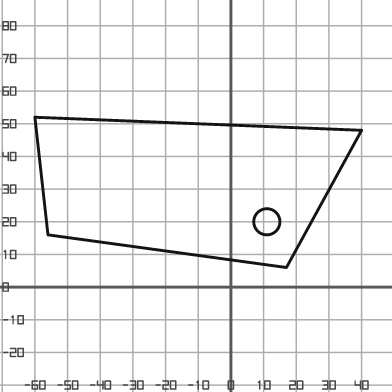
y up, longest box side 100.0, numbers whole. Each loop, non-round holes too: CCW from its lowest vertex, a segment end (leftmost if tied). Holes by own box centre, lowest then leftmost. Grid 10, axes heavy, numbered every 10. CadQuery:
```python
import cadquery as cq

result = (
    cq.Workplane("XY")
    .moveTo(17.0, 6.0)
    .lineTo(40.0, 48.0)
    .lineTo(-60.0, 52.0)
    .lineTo(-56.0, 16.0)
    .close()
    .moveTo(11.0, 20.0)
    .circle(4.0)
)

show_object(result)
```